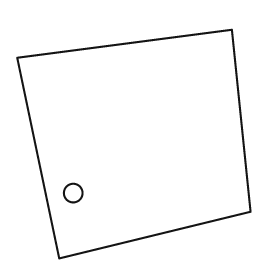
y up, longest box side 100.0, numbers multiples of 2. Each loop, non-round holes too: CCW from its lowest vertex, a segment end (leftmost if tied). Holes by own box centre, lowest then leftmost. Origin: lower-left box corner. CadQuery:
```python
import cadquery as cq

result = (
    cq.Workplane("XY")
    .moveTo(18.0, 0.0)
    .lineTo(100.0, 20.0)
    .lineTo(92.0, 98.0)
    .lineTo(0.0, 86.0)
    .close()
    .moveTo(24.0, 28.0)
    .circle(4.0)
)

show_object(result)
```